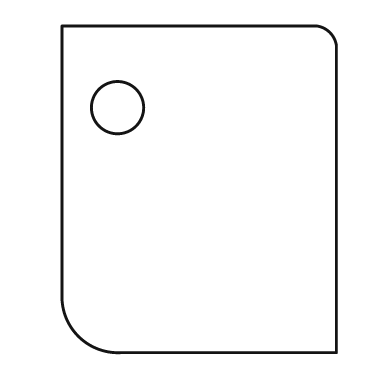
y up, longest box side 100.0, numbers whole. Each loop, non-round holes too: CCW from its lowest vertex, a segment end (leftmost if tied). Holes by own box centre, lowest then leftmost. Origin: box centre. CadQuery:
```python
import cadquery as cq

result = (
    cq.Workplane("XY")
    .moveTo(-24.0, -50.0)
    .lineTo(42.0, -50.0)
    .lineTo(42.0, 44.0)
    .threePointArc((40.0, 48.0), (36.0, 50.0))
    .lineTo(-42.0, 50.0)
    .lineTo(-42.0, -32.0)
    .threePointArc((-37.0, -45.0), (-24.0, -50.0))
    .close()
    .moveTo(-25.0, 25.0)
    .circle(8.0)
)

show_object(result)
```